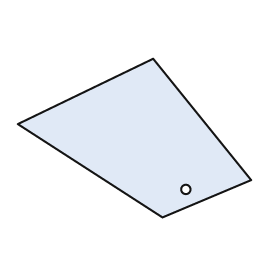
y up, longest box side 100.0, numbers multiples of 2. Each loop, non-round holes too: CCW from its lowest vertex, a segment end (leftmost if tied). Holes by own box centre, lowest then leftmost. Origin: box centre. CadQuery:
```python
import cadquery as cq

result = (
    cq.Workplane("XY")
    .moveTo(12.0, -34.0)
    .lineTo(50.0, -18.0)
    .lineTo(8.0, 34.0)
    .lineTo(-50.0, 6.0)
    .close()
    .moveTo(22.0, -22.0)
    .circle(2.0)
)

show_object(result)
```